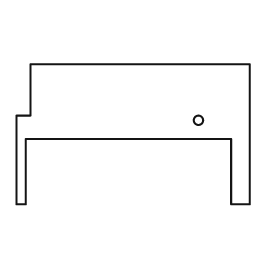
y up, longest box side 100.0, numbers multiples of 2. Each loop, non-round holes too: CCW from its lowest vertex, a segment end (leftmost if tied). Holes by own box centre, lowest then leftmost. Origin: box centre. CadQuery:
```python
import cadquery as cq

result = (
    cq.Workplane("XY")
    .moveTo(-50.0, -30.0)
    .lineTo(-46.0, -30.0)
    .lineTo(-46.0, -2.0)
    .lineTo(42.0, -2.0)
    .lineTo(42.0, -30.0)
    .lineTo(50.0, -30.0)
    .lineTo(50.0, 30.0)
    .lineTo(-44.0, 30.0)
    .lineTo(-44.0, 8.0)
    .lineTo(-50.0, 8.0)
    .close()
    .moveTo(28.0, 6.0)
    .circle(2.0)
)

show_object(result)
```